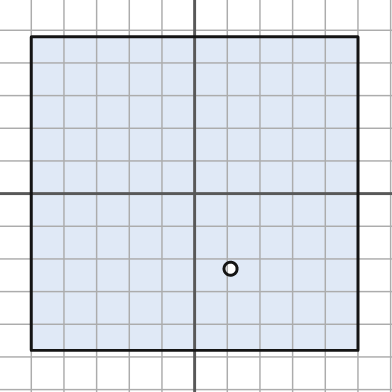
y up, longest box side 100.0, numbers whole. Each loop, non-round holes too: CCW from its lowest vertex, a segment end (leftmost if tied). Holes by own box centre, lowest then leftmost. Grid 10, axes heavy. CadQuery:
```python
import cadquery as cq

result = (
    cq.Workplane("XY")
    .moveTo(-50.0, -48.0)
    .lineTo(50.0, -48.0)
    .lineTo(50.0, 48.0)
    .lineTo(-50.0, 48.0)
    .close()
    .moveTo(11.0, -23.0)
    .circle(2.0)
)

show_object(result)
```